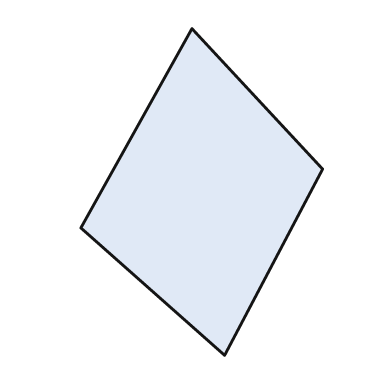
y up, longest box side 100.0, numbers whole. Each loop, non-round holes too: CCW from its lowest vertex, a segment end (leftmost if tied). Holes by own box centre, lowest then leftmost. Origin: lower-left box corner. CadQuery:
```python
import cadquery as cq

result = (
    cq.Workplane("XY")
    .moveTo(44.0, 0.0)
    .lineTo(74.0, 57.0)
    .lineTo(34.0, 100.0)
    .lineTo(0.0, 39.0)
    .close()
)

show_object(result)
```